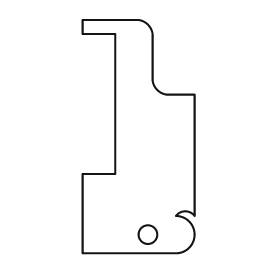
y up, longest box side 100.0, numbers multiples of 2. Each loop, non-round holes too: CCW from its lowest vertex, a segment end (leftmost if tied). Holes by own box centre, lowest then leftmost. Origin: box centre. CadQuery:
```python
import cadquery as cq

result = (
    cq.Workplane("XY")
    .moveTo(-24.0, -50.0)
    .lineTo(16.0, -50.0)
    .threePointArc((24.0, -42.0), (16.0, -34.0))
    .threePointArc((20.0, -32.0), (24.0, -34.0))
    .lineTo(24.0, 18.0)
    .lineTo(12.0, 18.0)
    .threePointArc((8.0, 20.0), (6.0, 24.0))
    .lineTo(6.0, 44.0)
    .threePointArc((4.0, 48.0), (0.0, 50.0))
    .lineTo(-24.0, 50.0)
    .lineTo(-24.0, 44.0)
    .lineTo(-10.0, 44.0)
    .lineTo(-10.0, -16.0)
    .lineTo(-24.0, -16.0)
    .close()
    .moveTo(4.0, -42.0)
    .circle(4.0)
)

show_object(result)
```